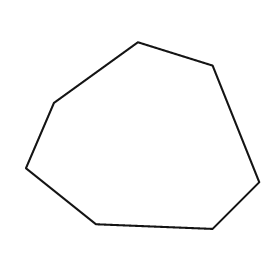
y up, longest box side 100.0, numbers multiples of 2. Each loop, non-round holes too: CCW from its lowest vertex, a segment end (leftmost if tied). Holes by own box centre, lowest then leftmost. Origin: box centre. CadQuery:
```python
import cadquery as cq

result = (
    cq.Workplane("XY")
    .moveTo(30.0, -40.0)
    .lineTo(50.0, -20.0)
    .lineTo(30.0, 30.0)
    .lineTo(-2.0, 40.0)
    .lineTo(-38.0, 14.0)
    .lineTo(-50.0, -14.0)
    .lineTo(-20.0, -38.0)
    .close()
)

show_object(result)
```